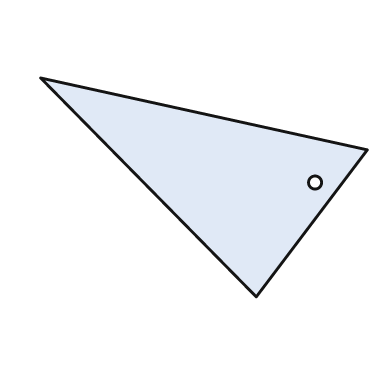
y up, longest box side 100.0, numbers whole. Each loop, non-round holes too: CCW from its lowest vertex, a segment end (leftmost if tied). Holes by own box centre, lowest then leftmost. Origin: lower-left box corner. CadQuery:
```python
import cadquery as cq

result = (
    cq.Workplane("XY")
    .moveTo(66.0, 0.0)
    .lineTo(100.0, 45.0)
    .lineTo(0.0, 67.0)
    .close()
    .moveTo(84.0, 35.0)
    .circle(2.0)
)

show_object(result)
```